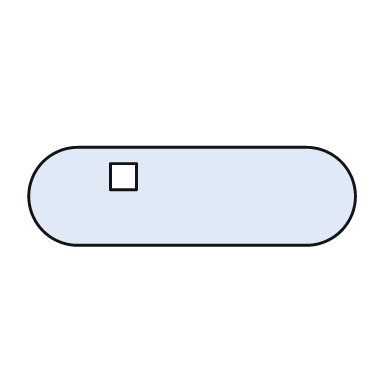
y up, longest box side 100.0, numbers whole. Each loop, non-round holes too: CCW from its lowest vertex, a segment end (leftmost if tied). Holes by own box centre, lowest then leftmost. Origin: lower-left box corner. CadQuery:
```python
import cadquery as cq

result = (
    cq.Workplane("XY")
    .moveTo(15.0, 0.0)
    .lineTo(85.0, 0.0)
    .threePointArc((100.0, 15.0), (85.0, 30.0))
    .lineTo(15.0, 30.0)
    .threePointArc((0.0, 15.0), (15.0, 0.0))
    .close()
    .moveTo(25.0, 17.0)
    .lineTo(33.0, 17.0)
    .lineTo(33.0, 25.0)
    .lineTo(25.0, 25.0)
    .close()
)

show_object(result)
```